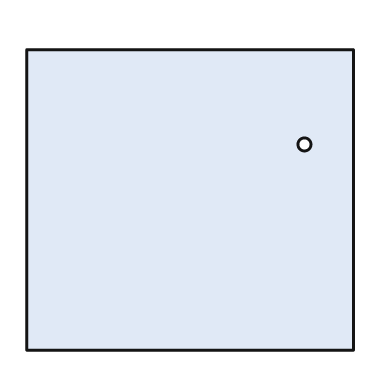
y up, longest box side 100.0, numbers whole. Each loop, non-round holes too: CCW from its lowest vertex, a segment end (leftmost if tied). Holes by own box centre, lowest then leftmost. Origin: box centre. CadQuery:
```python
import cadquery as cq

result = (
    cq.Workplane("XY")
    .moveTo(-50.0, -46.0)
    .lineTo(50.0, -46.0)
    .lineTo(50.0, 46.0)
    .lineTo(-50.0, 46.0)
    .close()
    .moveTo(35.0, 17.0)
    .circle(2.0)
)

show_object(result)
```